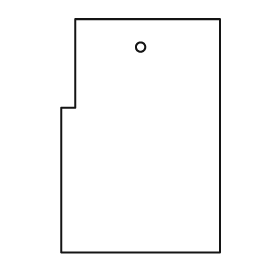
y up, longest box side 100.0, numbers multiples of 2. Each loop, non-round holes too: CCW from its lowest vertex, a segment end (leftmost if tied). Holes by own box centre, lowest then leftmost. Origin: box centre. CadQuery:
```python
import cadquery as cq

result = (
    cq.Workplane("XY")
    .moveTo(-34.0, -50.0)
    .lineTo(34.0, -50.0)
    .lineTo(34.0, 50.0)
    .lineTo(-28.0, 50.0)
    .lineTo(-28.0, 12.0)
    .lineTo(-34.0, 12.0)
    .close()
    .moveTo(0.0, 38.0)
    .circle(2.0)
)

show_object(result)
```